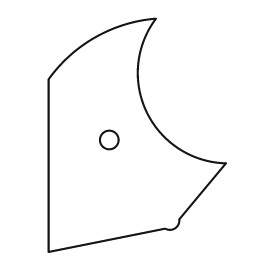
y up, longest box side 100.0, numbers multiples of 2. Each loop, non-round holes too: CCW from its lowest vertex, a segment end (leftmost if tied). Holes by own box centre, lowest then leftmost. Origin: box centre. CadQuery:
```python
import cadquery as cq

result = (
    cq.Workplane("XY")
    .moveTo(-38.0, -50.0)
    .lineTo(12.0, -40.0)
    .threePointArc((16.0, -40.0), (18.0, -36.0))
    .lineTo(38.0, -12.0)
    .threePointArc((4.0, 10.0), (8.0, 50.0))
    .threePointArc((-18.0, 42.0), (-38.0, 24.0))
    .close()
    .moveTo(-12.0, -2.0)
    .circle(4.0)
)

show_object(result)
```